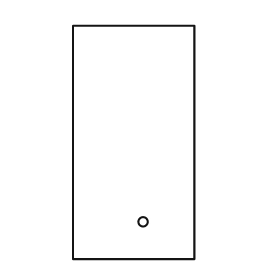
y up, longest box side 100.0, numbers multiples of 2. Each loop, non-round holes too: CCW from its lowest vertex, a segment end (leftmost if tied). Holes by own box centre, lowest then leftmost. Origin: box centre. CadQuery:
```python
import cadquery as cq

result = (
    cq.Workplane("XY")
    .moveTo(-26.0, -50.0)
    .lineTo(26.0, -50.0)
    .lineTo(26.0, 50.0)
    .lineTo(-26.0, 50.0)
    .close()
    .moveTo(4.0, -34.0)
    .circle(2.0)
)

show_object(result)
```